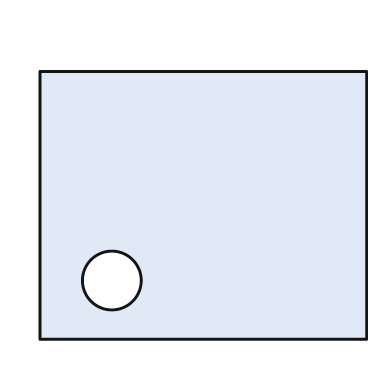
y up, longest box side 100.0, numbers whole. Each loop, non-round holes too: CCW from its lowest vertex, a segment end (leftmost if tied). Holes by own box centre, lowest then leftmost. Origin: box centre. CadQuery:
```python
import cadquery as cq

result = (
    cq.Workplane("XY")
    .moveTo(-50.0, -41.0)
    .lineTo(50.0, -41.0)
    .lineTo(50.0, 41.0)
    .lineTo(-50.0, 41.0)
    .close()
    .moveTo(-28.0, -23.0)
    .circle(9.0)
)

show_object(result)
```